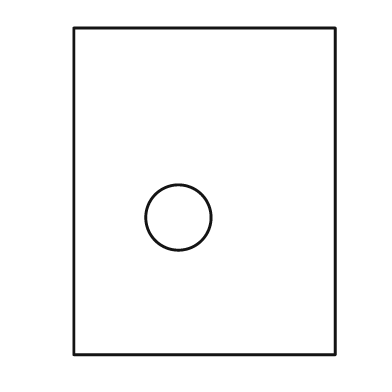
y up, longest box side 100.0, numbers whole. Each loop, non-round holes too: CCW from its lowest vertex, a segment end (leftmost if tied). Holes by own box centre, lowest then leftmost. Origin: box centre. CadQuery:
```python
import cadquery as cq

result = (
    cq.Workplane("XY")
    .moveTo(-40.0, -50.0)
    .lineTo(40.0, -50.0)
    .lineTo(40.0, 50.0)
    .lineTo(-40.0, 50.0)
    .close()
    .moveTo(-8.0, -8.0)
    .circle(10.0)
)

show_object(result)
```